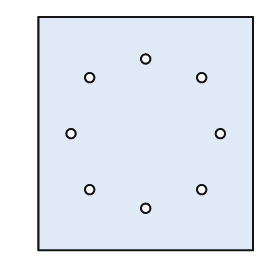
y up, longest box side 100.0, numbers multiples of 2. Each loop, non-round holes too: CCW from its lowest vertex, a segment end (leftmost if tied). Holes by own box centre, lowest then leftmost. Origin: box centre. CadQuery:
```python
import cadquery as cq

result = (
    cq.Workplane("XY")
    .moveTo(-46.0, -50.0)
    .lineTo(46.0, -50.0)
    .lineTo(46.0, 50.0)
    .lineTo(-46.0, 50.0)
    .close()
    .moveTo(0.0, -32.0)
    .circle(2.0)
    .moveTo(-24.0, -24.0)
    .circle(2.0)
    .moveTo(24.0, -24.0)
    .circle(2.0)
    .moveTo(-32.0, 0.0)
    .circle(2.0)
    .moveTo(32.0, 0.0)
    .circle(2.0)
    .moveTo(-24.0, 24.0)
    .circle(2.0)
    .moveTo(24.0, 24.0)
    .circle(2.0)
    .moveTo(0.0, 32.0)
    .circle(2.0)
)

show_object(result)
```